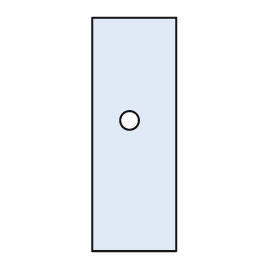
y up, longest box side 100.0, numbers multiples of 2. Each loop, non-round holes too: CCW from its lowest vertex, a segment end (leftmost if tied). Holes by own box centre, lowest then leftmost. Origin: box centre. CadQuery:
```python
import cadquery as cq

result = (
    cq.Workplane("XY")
    .moveTo(-18.0, -50.0)
    .lineTo(18.0, -50.0)
    .lineTo(18.0, 50.0)
    .lineTo(-18.0, 50.0)
    .close()
    .moveTo(-2.0, 6.0)
    .circle(4.0)
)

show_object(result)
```